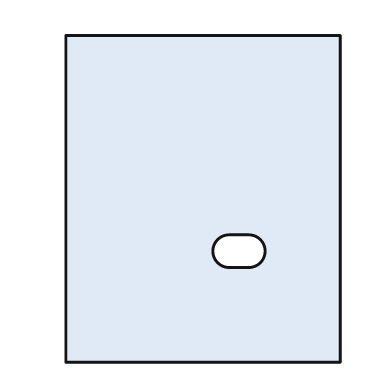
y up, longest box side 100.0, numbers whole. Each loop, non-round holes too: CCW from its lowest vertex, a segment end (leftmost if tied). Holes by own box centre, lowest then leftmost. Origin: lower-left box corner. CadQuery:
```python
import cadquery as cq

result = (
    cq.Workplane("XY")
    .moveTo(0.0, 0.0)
    .lineTo(84.0, 0.0)
    .lineTo(84.0, 100.0)
    .lineTo(0.0, 100.0)
    .close()
    .moveTo(50.0, 29.0)
    .lineTo(56.0, 29.0)
    .threePointArc((61.0, 34.0), (56.0, 39.0))
    .lineTo(50.0, 39.0)
    .threePointArc((45.0, 34.0), (50.0, 29.0))
    .close()
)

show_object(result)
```